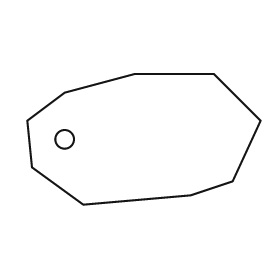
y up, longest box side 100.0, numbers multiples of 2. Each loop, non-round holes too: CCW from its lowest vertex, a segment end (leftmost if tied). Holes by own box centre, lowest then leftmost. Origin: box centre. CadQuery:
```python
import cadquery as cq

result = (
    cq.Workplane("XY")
    .moveTo(-26.0, -28.0)
    .lineTo(20.0, -24.0)
    .lineTo(38.0, -18.0)
    .lineTo(50.0, 8.0)
    .lineTo(30.0, 28.0)
    .lineTo(-4.0, 28.0)
    .lineTo(-34.0, 20.0)
    .lineTo(-50.0, 8.0)
    .lineTo(-48.0, -12.0)
    .close()
    .moveTo(-34.0, 0.0)
    .circle(4.0)
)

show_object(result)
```